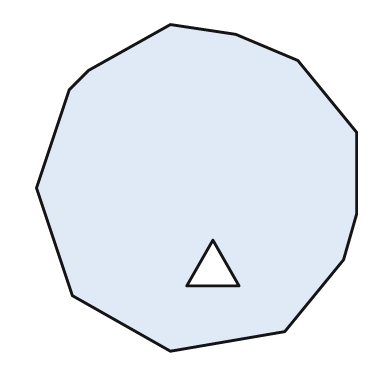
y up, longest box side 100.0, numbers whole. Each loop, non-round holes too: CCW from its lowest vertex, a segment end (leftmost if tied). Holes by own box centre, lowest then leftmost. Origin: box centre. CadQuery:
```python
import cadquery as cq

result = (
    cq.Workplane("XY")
    .moveTo(-8.0, -50.0)
    .lineTo(27.0, -44.0)
    .lineTo(45.0, -22.0)
    .lineTo(49.0, -8.0)
    .lineTo(49.0, 17.0)
    .lineTo(31.0, 39.0)
    .lineTo(12.0, 47.0)
    .lineTo(-8.0, 50.0)
    .lineTo(-33.0, 36.0)
    .lineTo(-39.0, 30.0)
    .lineTo(-49.0, 0.0)
    .lineTo(-38.0, -33.0)
    .close()
    .moveTo(-3.0, -30.0)
    .lineTo(13.0, -30.0)
    .lineTo(5.0, -16.0)
    .close()
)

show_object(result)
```